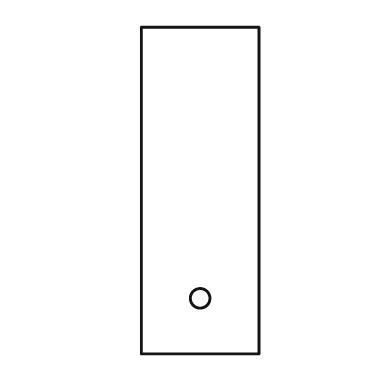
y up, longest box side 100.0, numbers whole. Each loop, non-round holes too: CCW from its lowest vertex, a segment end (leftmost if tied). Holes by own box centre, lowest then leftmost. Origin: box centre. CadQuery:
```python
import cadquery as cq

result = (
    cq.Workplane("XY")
    .moveTo(-18.0, -50.0)
    .lineTo(18.0, -50.0)
    .lineTo(18.0, 50.0)
    .lineTo(-18.0, 50.0)
    .close()
    .moveTo(0.0, -33.0)
    .circle(3.0)
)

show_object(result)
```